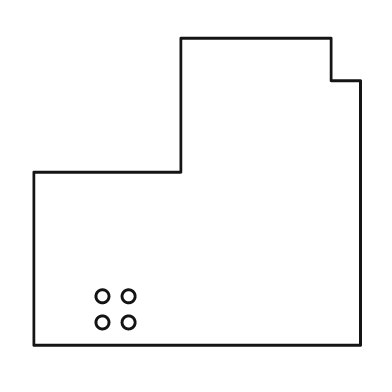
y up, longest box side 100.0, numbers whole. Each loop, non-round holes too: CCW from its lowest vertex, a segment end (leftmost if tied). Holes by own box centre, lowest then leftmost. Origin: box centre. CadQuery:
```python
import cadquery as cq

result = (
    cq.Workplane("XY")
    .moveTo(-50.0, -47.0)
    .lineTo(50.0, -47.0)
    .lineTo(50.0, 34.0)
    .lineTo(41.0, 34.0)
    .lineTo(41.0, 47.0)
    .lineTo(-5.0, 47.0)
    .lineTo(-5.0, 6.0)
    .lineTo(-50.0, 6.0)
    .close()
    .moveTo(-29.0, -40.0)
    .circle(2.0)
    .moveTo(-21.0, -40.0)
    .circle(2.0)
    .moveTo(-29.0, -32.0)
    .circle(2.0)
    .moveTo(-21.0, -32.0)
    .circle(2.0)
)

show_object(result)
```